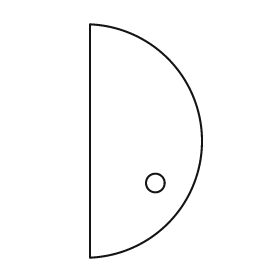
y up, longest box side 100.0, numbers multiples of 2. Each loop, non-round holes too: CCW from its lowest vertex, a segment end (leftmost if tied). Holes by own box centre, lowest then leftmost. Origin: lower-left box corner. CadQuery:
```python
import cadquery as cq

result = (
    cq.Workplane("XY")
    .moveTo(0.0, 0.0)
    .threePointArc((48.0, 50.0), (0.0, 100.0))
    .close()
    .moveTo(28.0, 32.0)
    .circle(4.0)
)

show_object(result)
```